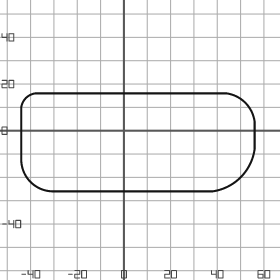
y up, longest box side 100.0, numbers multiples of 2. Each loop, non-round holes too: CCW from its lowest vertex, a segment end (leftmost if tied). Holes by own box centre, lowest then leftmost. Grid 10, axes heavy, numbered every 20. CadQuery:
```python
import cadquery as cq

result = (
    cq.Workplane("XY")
    .moveTo(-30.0, -26.0)
    .lineTo(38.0, -26.0)
    .threePointArc((50.0, -20.0), (56.0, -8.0))
    .lineTo(56.0, 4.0)
    .threePointArc((52.0, 12.0), (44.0, 16.0))
    .lineTo(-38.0, 16.0)
    .threePointArc((-42.0, 14.0), (-44.0, 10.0))
    .lineTo(-44.0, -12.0)
    .threePointArc((-40.0, -22.0), (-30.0, -26.0))
    .close()
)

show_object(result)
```